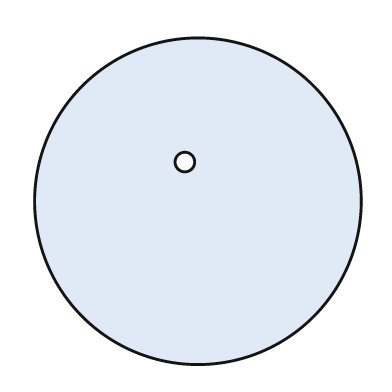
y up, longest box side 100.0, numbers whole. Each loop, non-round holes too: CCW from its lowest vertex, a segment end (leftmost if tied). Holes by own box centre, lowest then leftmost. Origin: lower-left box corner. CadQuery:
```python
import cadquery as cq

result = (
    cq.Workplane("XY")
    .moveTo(50.0, 50.0)
    .circle(50.0)
    .moveTo(46.0, 62.0)
    .circle(3.0)
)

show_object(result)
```